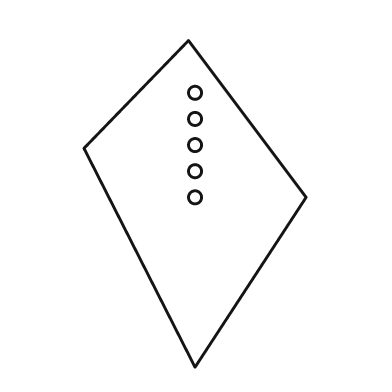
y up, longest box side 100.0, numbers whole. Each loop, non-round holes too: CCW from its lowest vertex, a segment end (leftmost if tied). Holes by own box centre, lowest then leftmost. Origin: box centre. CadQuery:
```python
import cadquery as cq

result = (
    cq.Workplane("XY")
    .moveTo(0.0, -50.0)
    .lineTo(34.0, 2.0)
    .lineTo(-2.0, 50.0)
    .lineTo(-34.0, 17.0)
    .close()
    .moveTo(0.0, 2.0)
    .circle(2.0)
    .moveTo(0.0, 10.0)
    .circle(2.0)
    .moveTo(0.0, 18.0)
    .circle(2.0)
    .moveTo(0.0, 26.0)
    .circle(2.0)
    .moveTo(0.0, 34.0)
    .circle(2.0)
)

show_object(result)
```